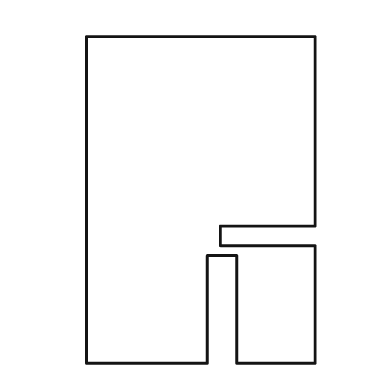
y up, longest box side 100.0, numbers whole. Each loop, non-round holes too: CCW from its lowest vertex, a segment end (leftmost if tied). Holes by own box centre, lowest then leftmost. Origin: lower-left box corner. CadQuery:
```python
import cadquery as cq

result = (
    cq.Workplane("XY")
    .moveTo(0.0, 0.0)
    .lineTo(37.0, 0.0)
    .lineTo(37.0, 33.0)
    .lineTo(46.0, 33.0)
    .lineTo(46.0, 0.0)
    .lineTo(70.0, 0.0)
    .lineTo(70.0, 36.0)
    .lineTo(41.0, 36.0)
    .lineTo(41.0, 42.0)
    .lineTo(70.0, 42.0)
    .lineTo(70.0, 100.0)
    .lineTo(0.0, 100.0)
    .close()
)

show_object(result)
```